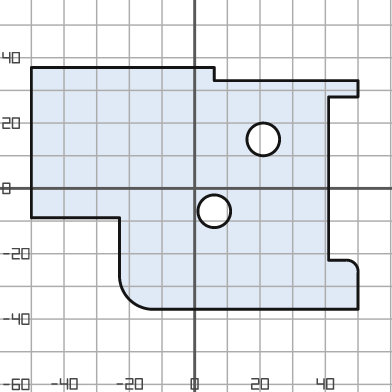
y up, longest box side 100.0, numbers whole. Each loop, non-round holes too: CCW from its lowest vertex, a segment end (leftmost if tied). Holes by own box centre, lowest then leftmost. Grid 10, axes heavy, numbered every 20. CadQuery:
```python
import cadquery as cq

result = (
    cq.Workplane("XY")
    .moveTo(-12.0, -37.0)
    .lineTo(50.0, -37.0)
    .lineTo(50.0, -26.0)
    .threePointArc((49.0, -23.0), (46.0, -22.0))
    .lineTo(41.0, -22.0)
    .lineTo(41.0, 28.0)
    .lineTo(50.0, 28.0)
    .lineTo(50.0, 33.0)
    .lineTo(6.0, 33.0)
    .lineTo(6.0, 37.0)
    .lineTo(-50.0, 37.0)
    .lineTo(-50.0, -9.0)
    .lineTo(-23.0, -9.0)
    .lineTo(-23.0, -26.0)
    .threePointArc((-20.0, -34.0), (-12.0, -37.0))
    .close()
    .moveTo(6.0, -7.0)
    .circle(5.0)
    .moveTo(21.0, 15.0)
    .circle(5.0)
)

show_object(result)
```